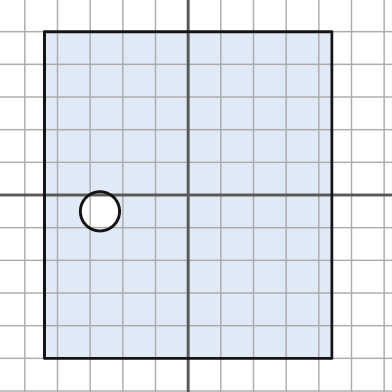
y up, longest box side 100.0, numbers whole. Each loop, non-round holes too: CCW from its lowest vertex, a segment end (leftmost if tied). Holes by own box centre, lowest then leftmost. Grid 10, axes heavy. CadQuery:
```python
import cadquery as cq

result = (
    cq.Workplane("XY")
    .moveTo(-44.0, -50.0)
    .lineTo(44.0, -50.0)
    .lineTo(44.0, 50.0)
    .lineTo(-44.0, 50.0)
    .close()
    .moveTo(-27.0, -5.0)
    .circle(6.0)
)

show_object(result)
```